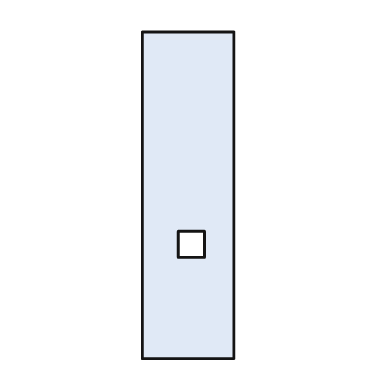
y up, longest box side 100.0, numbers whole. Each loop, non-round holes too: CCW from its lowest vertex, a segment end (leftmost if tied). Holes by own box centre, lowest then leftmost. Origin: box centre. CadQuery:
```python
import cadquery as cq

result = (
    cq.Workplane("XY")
    .moveTo(-14.0, -50.0)
    .lineTo(14.0, -50.0)
    .lineTo(14.0, 50.0)
    .lineTo(-14.0, 50.0)
    .close()
    .moveTo(-3.0, -19.0)
    .lineTo(5.0, -19.0)
    .lineTo(5.0, -11.0)
    .lineTo(-3.0, -11.0)
    .close()
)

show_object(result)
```